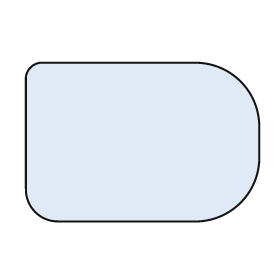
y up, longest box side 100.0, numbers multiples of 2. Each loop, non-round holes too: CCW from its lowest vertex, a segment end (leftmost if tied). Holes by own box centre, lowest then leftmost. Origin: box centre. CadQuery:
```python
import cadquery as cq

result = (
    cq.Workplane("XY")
    .moveTo(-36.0, -34.0)
    .lineTo(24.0, -34.0)
    .threePointArc((42.0, -26.0), (50.0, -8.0))
    .lineTo(50.0, 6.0)
    .threePointArc((42.0, 26.0), (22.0, 34.0))
    .lineTo(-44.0, 34.0)
    .threePointArc((-48.0, 32.0), (-50.0, 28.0))
    .lineTo(-50.0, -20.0)
    .threePointArc((-46.0, -30.0), (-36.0, -34.0))
    .close()
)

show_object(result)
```